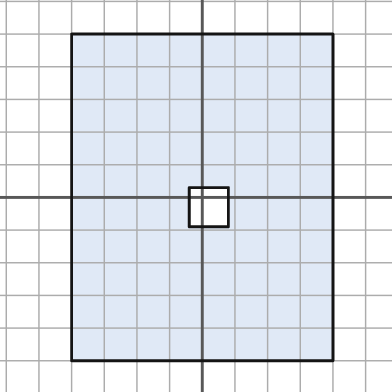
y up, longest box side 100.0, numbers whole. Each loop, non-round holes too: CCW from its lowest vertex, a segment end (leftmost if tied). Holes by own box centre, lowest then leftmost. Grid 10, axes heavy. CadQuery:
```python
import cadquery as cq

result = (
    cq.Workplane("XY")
    .moveTo(-40.0, -50.0)
    .lineTo(40.0, -50.0)
    .lineTo(40.0, 50.0)
    .lineTo(-40.0, 50.0)
    .close()
    .moveTo(-4.0, -9.0)
    .lineTo(8.0, -9.0)
    .lineTo(8.0, 3.0)
    .lineTo(-4.0, 3.0)
    .close()
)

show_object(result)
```